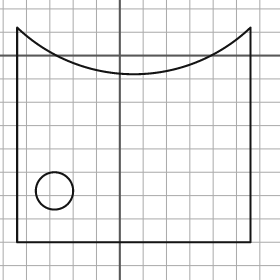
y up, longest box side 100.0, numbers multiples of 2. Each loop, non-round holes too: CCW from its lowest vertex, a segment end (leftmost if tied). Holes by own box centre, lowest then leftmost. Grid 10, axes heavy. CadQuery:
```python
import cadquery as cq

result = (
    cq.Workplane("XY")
    .moveTo(-44.0, -80.0)
    .lineTo(56.0, -80.0)
    .lineTo(56.0, 12.0)
    .threePointArc((6.0, -8.0), (-44.0, 12.0))
    .close()
    .moveTo(-28.0, -58.0)
    .circle(8.0)
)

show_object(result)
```